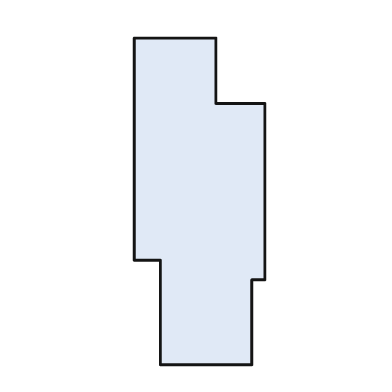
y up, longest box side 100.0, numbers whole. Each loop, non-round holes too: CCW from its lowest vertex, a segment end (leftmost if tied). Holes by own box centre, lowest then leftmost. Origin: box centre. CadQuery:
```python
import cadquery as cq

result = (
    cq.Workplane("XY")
    .moveTo(-12.0, -50.0)
    .lineTo(16.0, -50.0)
    .lineTo(16.0, -24.0)
    .lineTo(20.0, -24.0)
    .lineTo(20.0, 30.0)
    .lineTo(5.0, 30.0)
    .lineTo(5.0, 50.0)
    .lineTo(-20.0, 50.0)
    .lineTo(-20.0, -18.0)
    .lineTo(-12.0, -18.0)
    .close()
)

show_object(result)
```